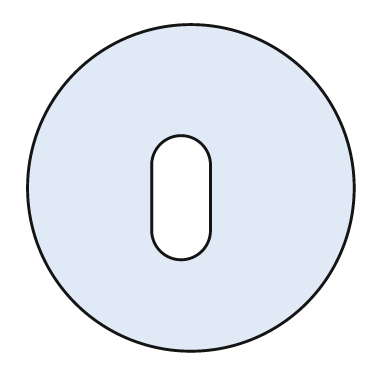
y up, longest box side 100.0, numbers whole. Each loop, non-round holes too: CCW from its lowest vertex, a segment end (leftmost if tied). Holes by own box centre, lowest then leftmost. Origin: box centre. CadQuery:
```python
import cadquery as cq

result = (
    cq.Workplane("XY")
    .moveTo(0.0, 0.0)
    .circle(50.0)
    .moveTo(-12.0, -13.0)
    .threePointArc((-3.0, -22.0), (6.0, -13.0))
    .lineTo(6.0, 7.0)
    .threePointArc((-3.0, 16.0), (-12.0, 7.0))
    .close()
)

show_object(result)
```